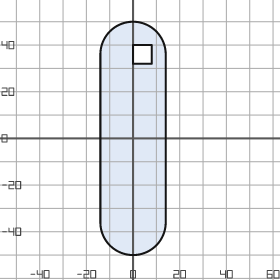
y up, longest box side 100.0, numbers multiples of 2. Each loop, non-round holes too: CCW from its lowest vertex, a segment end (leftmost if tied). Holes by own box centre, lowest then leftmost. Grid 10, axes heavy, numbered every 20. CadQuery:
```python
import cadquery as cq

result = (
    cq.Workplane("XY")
    .moveTo(-14.0, -36.0)
    .threePointArc((0.0, -50.0), (14.0, -36.0))
    .lineTo(14.0, 36.0)
    .threePointArc((0.0, 50.0), (-14.0, 36.0))
    .close()
    .moveTo(0.0, 32.0)
    .lineTo(8.0, 32.0)
    .lineTo(8.0, 40.0)
    .lineTo(0.0, 40.0)
    .close()
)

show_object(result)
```